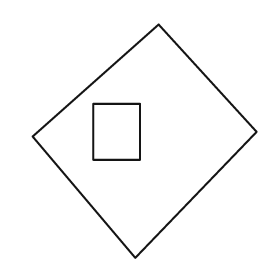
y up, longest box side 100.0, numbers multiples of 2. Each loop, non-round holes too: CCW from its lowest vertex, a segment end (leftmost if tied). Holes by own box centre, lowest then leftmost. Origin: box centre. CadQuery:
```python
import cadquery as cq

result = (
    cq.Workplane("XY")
    .moveTo(-4.0, -50.0)
    .lineTo(48.0, 4.0)
    .lineTo(6.0, 50.0)
    .lineTo(-48.0, 2.0)
    .close()
    .moveTo(-22.0, -8.0)
    .lineTo(-2.0, -8.0)
    .lineTo(-2.0, 16.0)
    .lineTo(-22.0, 16.0)
    .close()
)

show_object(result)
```